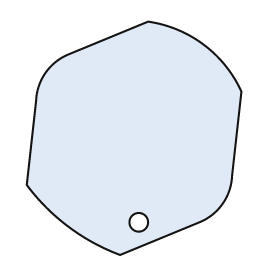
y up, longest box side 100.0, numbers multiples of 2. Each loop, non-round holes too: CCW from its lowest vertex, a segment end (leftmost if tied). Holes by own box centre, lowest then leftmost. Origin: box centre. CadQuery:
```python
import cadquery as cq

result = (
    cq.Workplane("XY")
    .moveTo(-6.0, -50.0)
    .lineTo(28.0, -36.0)
    .threePointArc((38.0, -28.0), (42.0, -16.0))
    .lineTo(46.0, 20.0)
    .threePointArc((30.0, 40.0), (6.0, 50.0))
    .lineTo(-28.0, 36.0)
    .threePointArc((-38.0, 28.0), (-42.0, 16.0))
    .lineTo(-46.0, -20.0)
    .threePointArc((-28.0, -38.0), (-6.0, -50.0))
    .close()
    .moveTo(2.0, -36.0)
    .circle(4.0)
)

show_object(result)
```